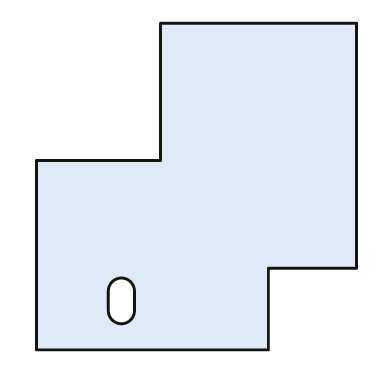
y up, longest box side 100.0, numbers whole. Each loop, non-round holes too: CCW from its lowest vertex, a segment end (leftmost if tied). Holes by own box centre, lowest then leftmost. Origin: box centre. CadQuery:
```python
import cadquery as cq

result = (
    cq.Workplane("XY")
    .moveTo(-49.0, -50.0)
    .lineTo(22.0, -50.0)
    .lineTo(22.0, -25.0)
    .lineTo(49.0, -25.0)
    .lineTo(49.0, 50.0)
    .lineTo(-11.0, 50.0)
    .lineTo(-11.0, 8.0)
    .lineTo(-49.0, 8.0)
    .close()
    .moveTo(-27.0, -38.0)
    .threePointArc((-23.0, -42.0), (-19.0, -38.0))
    .lineTo(-19.0, -32.0)
    .threePointArc((-23.0, -28.0), (-27.0, -32.0))
    .close()
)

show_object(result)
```